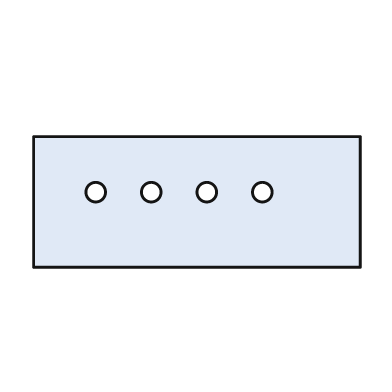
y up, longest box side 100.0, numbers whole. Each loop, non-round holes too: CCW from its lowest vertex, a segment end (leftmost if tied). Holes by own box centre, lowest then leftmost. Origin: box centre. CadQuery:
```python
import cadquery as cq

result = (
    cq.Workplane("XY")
    .moveTo(-50.0, -20.0)
    .lineTo(50.0, -20.0)
    .lineTo(50.0, 20.0)
    .lineTo(-50.0, 20.0)
    .close()
    .moveTo(-31.0, 3.0)
    .circle(3.0)
    .moveTo(-14.0, 3.0)
    .circle(3.0)
    .moveTo(3.0, 3.0)
    .circle(3.0)
    .moveTo(20.0, 3.0)
    .circle(3.0)
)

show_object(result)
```